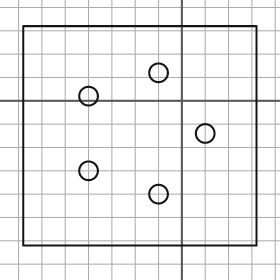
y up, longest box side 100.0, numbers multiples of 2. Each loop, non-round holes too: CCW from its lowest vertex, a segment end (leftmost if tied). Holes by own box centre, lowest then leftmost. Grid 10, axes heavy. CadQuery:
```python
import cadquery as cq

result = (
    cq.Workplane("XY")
    .moveTo(-68.0, -62.0)
    .lineTo(32.0, -62.0)
    .lineTo(32.0, 32.0)
    .lineTo(-68.0, 32.0)
    .close()
    .moveTo(-10.0, -40.0)
    .circle(4.0)
    .moveTo(-40.0, -30.0)
    .circle(4.0)
    .moveTo(10.0, -14.0)
    .circle(4.0)
    .moveTo(-40.0, 2.0)
    .circle(4.0)
    .moveTo(-10.0, 12.0)
    .circle(4.0)
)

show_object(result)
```